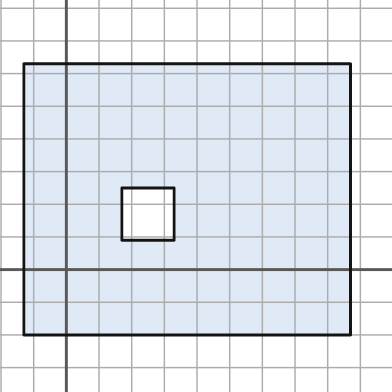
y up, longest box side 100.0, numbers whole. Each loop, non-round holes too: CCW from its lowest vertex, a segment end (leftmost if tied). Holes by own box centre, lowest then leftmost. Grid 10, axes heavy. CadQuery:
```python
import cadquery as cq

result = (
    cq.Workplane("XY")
    .moveTo(-13.0, -20.0)
    .lineTo(87.0, -20.0)
    .lineTo(87.0, 63.0)
    .lineTo(-13.0, 63.0)
    .close()
    .moveTo(17.0, 9.0)
    .lineTo(33.0, 9.0)
    .lineTo(33.0, 25.0)
    .lineTo(17.0, 25.0)
    .close()
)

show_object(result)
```